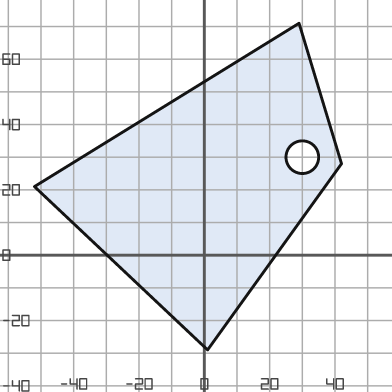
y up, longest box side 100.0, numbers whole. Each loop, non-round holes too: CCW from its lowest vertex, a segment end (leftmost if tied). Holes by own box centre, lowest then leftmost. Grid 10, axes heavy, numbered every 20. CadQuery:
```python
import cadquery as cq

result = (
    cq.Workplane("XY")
    .moveTo(1.0, -29.0)
    .lineTo(42.0, 28.0)
    .lineTo(29.0, 71.0)
    .lineTo(-52.0, 21.0)
    .close()
    .moveTo(30.0, 30.0)
    .circle(5.0)
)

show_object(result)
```